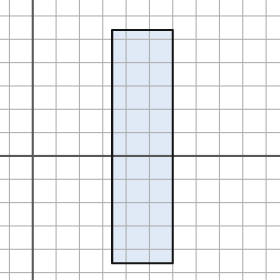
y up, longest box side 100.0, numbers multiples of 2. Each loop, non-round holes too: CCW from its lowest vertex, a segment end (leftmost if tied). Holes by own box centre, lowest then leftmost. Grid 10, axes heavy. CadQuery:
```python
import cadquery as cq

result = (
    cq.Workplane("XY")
    .moveTo(34.0, -46.0)
    .lineTo(60.0, -46.0)
    .lineTo(60.0, 54.0)
    .lineTo(34.0, 54.0)
    .close()
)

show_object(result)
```